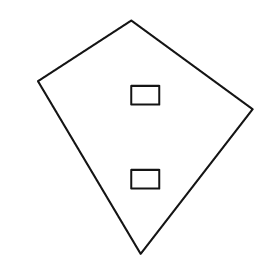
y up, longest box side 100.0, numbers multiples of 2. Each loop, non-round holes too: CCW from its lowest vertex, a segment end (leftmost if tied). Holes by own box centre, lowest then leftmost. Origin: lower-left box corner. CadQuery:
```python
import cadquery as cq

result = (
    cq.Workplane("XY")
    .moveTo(44.0, 0.0)
    .lineTo(92.0, 62.0)
    .lineTo(40.0, 100.0)
    .lineTo(0.0, 74.0)
    .close()
    .moveTo(40.0, 28.0)
    .lineTo(52.0, 28.0)
    .lineTo(52.0, 36.0)
    .lineTo(40.0, 36.0)
    .close()
    .moveTo(40.0, 64.0)
    .lineTo(52.0, 64.0)
    .lineTo(52.0, 72.0)
    .lineTo(40.0, 72.0)
    .close()
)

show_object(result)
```